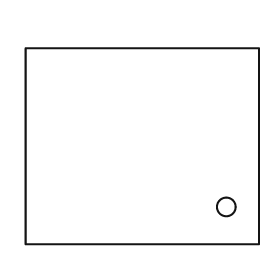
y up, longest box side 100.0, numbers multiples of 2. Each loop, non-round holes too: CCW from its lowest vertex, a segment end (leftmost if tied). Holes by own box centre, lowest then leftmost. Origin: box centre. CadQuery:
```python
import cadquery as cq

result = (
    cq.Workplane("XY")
    .moveTo(-50.0, -42.0)
    .lineTo(50.0, -42.0)
    .lineTo(50.0, 42.0)
    .lineTo(-50.0, 42.0)
    .close()
    .moveTo(36.0, -26.0)
    .circle(4.0)
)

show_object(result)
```